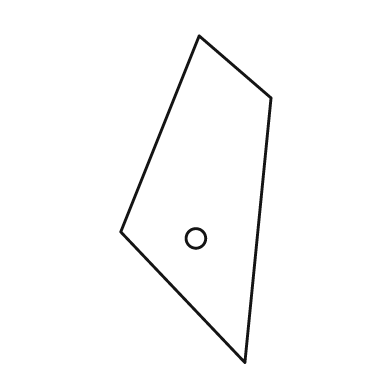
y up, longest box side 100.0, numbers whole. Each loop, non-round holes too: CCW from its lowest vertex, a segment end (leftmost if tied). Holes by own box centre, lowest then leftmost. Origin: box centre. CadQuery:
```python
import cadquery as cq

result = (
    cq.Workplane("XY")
    .moveTo(15.0, -50.0)
    .lineTo(23.0, 31.0)
    .lineTo(1.0, 50.0)
    .lineTo(-23.0, -10.0)
    .close()
    .moveTo(0.0, -12.0)
    .circle(3.0)
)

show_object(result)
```